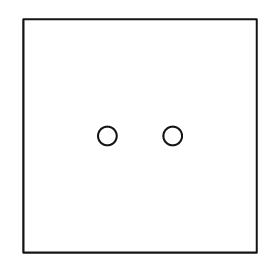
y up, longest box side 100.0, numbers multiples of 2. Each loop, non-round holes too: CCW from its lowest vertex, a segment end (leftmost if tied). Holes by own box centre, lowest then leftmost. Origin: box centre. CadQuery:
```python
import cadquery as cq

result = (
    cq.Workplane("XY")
    .moveTo(-50.0, -50.0)
    .lineTo(50.0, -50.0)
    .lineTo(50.0, 50.0)
    .lineTo(-50.0, 50.0)
    .close()
    .moveTo(-14.0, 0.0)
    .circle(4.0)
    .moveTo(14.0, 0.0)
    .circle(4.0)
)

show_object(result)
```